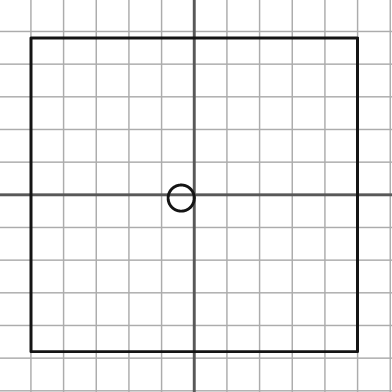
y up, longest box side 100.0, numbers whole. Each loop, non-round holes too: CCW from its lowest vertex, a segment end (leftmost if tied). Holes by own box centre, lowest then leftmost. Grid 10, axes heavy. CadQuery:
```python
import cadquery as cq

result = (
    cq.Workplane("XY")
    .moveTo(-50.0, -48.0)
    .lineTo(50.0, -48.0)
    .lineTo(50.0, 48.0)
    .lineTo(-50.0, 48.0)
    .close()
    .moveTo(-4.0, -1.0)
    .circle(4.0)
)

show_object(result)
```